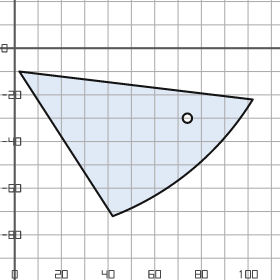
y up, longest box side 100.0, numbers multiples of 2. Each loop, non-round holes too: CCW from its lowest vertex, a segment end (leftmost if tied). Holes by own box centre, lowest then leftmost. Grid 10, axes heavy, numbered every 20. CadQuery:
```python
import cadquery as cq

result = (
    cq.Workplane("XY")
    .moveTo(42.0, -72.0)
    .threePointArc((76.0, -52.0), (102.0, -22.0))
    .lineTo(2.0, -10.0)
    .close()
    .moveTo(74.0, -30.0)
    .circle(2.0)
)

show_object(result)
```